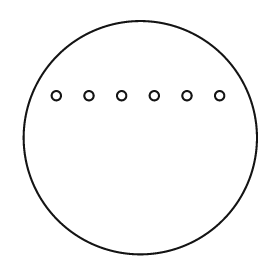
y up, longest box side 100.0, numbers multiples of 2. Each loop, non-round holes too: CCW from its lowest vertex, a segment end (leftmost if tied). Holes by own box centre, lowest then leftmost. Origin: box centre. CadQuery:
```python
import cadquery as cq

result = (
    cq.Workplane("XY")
    .moveTo(0.0, 0.0)
    .circle(50.0)
    .moveTo(-36.0, 18.0)
    .circle(2.0)
    .moveTo(-22.0, 18.0)
    .circle(2.0)
    .moveTo(-8.0, 18.0)
    .circle(2.0)
    .moveTo(6.0, 18.0)
    .circle(2.0)
    .moveTo(20.0, 18.0)
    .circle(2.0)
    .moveTo(34.0, 18.0)
    .circle(2.0)
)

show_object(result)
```